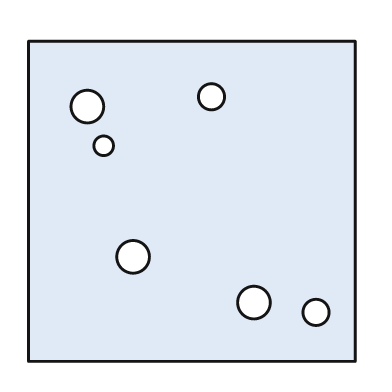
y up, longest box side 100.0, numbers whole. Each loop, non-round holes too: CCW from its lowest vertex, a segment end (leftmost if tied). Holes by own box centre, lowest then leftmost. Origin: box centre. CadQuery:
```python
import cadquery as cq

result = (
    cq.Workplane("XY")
    .moveTo(-50.0, -49.0)
    .lineTo(50.0, -49.0)
    .lineTo(50.0, 49.0)
    .lineTo(-50.0, 49.0)
    .close()
    .moveTo(38.0, -34.0)
    .circle(4.0)
    .moveTo(19.0, -31.0)
    .circle(5.0)
    .moveTo(-18.0, -17.0)
    .circle(5.0)
    .moveTo(-27.0, 17.0)
    .circle(3.0)
    .moveTo(-32.0, 29.0)
    .circle(5.0)
    .moveTo(6.0, 32.0)
    .circle(4.0)
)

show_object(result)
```